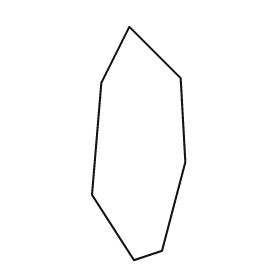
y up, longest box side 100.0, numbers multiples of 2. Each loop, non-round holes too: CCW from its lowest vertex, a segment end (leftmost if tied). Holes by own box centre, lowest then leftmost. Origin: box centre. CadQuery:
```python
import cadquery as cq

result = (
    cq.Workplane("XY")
    .moveTo(-2.0, -50.0)
    .lineTo(10.0, -46.0)
    .lineTo(20.0, -8.0)
    .lineTo(18.0, 28.0)
    .lineTo(-4.0, 50.0)
    .lineTo(-16.0, 26.0)
    .lineTo(-20.0, -22.0)
    .close()
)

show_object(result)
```